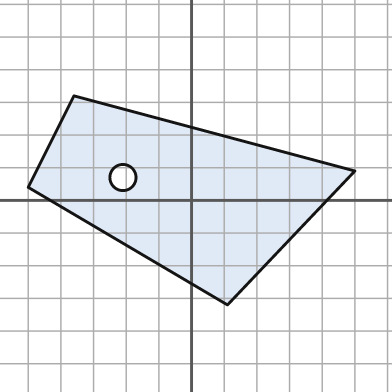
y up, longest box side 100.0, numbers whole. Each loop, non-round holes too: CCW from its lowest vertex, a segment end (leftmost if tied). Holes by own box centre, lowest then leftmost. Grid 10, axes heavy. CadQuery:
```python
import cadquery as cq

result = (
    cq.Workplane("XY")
    .moveTo(11.0, -32.0)
    .lineTo(50.0, 9.0)
    .lineTo(-36.0, 32.0)
    .lineTo(-50.0, 4.0)
    .close()
    .moveTo(-21.0, 7.0)
    .circle(4.0)
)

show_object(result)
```